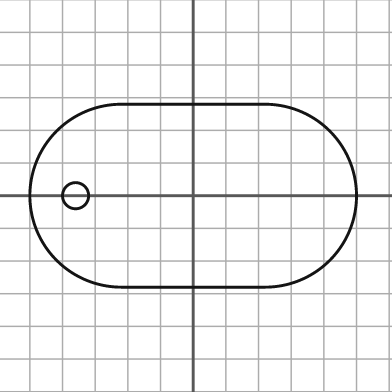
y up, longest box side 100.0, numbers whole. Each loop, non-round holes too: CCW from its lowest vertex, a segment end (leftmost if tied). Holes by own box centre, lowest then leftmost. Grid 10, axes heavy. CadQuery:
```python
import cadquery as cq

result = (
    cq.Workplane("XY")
    .moveTo(-22.0, -28.0)
    .lineTo(22.0, -28.0)
    .threePointArc((50.0, 0.0), (22.0, 28.0))
    .lineTo(-22.0, 28.0)
    .threePointArc((-50.0, 0.0), (-22.0, -28.0))
    .close()
    .moveTo(-36.0, 0.0)
    .circle(4.0)
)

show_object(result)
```